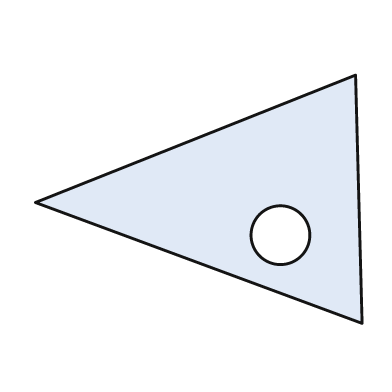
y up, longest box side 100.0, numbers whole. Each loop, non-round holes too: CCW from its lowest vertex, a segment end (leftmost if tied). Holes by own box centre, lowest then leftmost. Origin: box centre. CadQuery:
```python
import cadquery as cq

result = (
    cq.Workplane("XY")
    .moveTo(50.0, -38.0)
    .lineTo(48.0, 38.0)
    .lineTo(-50.0, -1.0)
    .close()
    .moveTo(25.0, -11.0)
    .circle(9.0)
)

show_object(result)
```